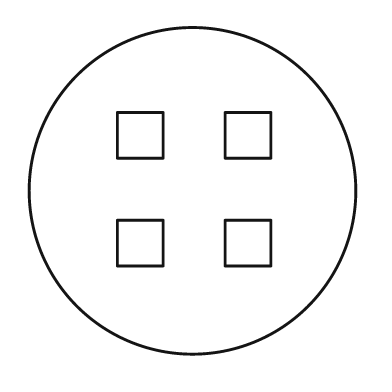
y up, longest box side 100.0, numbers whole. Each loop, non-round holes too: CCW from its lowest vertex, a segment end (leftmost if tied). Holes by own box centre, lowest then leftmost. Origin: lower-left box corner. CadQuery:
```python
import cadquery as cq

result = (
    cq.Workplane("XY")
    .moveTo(50.0, 50.0)
    .circle(50.0)
    .moveTo(27.0, 27.0)
    .lineTo(41.0, 27.0)
    .lineTo(41.0, 41.0)
    .lineTo(27.0, 41.0)
    .close()
    .moveTo(60.0, 27.0)
    .lineTo(74.0, 27.0)
    .lineTo(74.0, 41.0)
    .lineTo(60.0, 41.0)
    .close()
    .moveTo(27.0, 60.0)
    .lineTo(41.0, 60.0)
    .lineTo(41.0, 74.0)
    .lineTo(27.0, 74.0)
    .close()
    .moveTo(60.0, 60.0)
    .lineTo(74.0, 60.0)
    .lineTo(74.0, 74.0)
    .lineTo(60.0, 74.0)
    .close()
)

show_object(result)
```